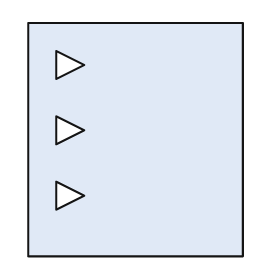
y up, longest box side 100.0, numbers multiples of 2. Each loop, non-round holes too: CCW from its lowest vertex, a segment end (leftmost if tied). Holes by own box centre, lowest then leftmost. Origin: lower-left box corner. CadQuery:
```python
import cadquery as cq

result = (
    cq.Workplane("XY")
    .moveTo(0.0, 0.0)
    .lineTo(92.0, 0.0)
    .lineTo(92.0, 100.0)
    .lineTo(0.0, 100.0)
    .close()
    .moveTo(12.0, 20.0)
    .lineTo(24.0, 26.0)
    .lineTo(12.0, 32.0)
    .close()
    .moveTo(12.0, 48.0)
    .lineTo(24.0, 54.0)
    .lineTo(12.0, 60.0)
    .close()
    .moveTo(12.0, 76.0)
    .lineTo(24.0, 82.0)
    .lineTo(12.0, 88.0)
    .close()
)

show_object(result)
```